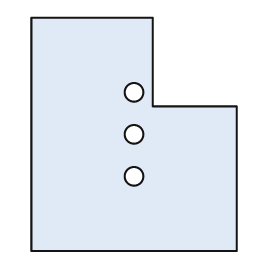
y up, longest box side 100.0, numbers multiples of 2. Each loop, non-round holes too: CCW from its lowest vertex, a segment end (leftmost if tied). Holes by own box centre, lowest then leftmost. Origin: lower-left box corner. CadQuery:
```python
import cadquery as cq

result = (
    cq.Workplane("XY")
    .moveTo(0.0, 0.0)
    .lineTo(88.0, 0.0)
    .lineTo(88.0, 62.0)
    .lineTo(52.0, 62.0)
    .lineTo(52.0, 100.0)
    .lineTo(0.0, 100.0)
    .close()
    .moveTo(44.0, 32.0)
    .circle(4.0)
    .moveTo(44.0, 50.0)
    .circle(4.0)
    .moveTo(44.0, 68.0)
    .circle(4.0)
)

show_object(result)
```